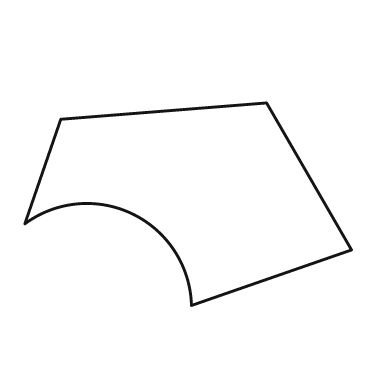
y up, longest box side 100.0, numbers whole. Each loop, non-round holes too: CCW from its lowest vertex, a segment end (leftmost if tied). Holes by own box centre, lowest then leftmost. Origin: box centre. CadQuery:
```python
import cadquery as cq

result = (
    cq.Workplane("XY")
    .moveTo(1.0, -31.0)
    .lineTo(50.0, -14.0)
    .lineTo(24.0, 31.0)
    .lineTo(-39.0, 26.0)
    .lineTo(-50.0, -6.0)
    .threePointArc((-17.0, -3.0), (1.0, -31.0))
    .close()
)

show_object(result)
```